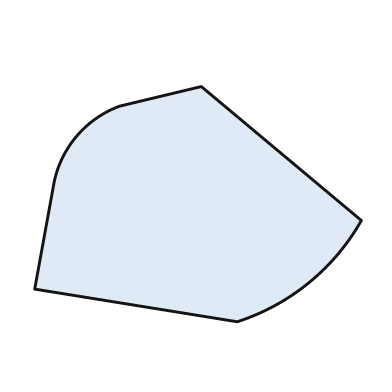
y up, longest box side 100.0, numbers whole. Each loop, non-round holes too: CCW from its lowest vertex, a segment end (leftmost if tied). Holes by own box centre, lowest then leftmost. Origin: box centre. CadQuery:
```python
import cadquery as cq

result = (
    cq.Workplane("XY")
    .moveTo(12.0, -36.0)
    .threePointArc((34.0, -24.0), (50.0, -5.0))
    .lineTo(1.0, 36.0)
    .lineTo(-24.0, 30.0)
    .threePointArc((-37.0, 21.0), (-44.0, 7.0))
    .lineTo(-50.0, -26.0)
    .close()
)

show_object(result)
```